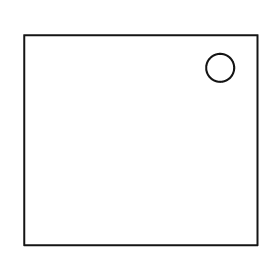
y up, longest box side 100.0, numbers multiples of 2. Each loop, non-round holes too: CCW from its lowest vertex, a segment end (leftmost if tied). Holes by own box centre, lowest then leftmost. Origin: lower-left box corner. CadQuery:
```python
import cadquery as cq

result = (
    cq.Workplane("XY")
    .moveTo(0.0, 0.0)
    .lineTo(100.0, 0.0)
    .lineTo(100.0, 90.0)
    .lineTo(0.0, 90.0)
    .close()
    .moveTo(84.0, 76.0)
    .circle(6.0)
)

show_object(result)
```